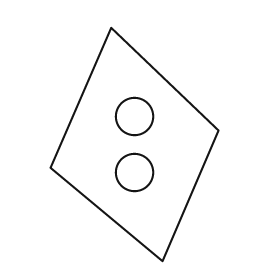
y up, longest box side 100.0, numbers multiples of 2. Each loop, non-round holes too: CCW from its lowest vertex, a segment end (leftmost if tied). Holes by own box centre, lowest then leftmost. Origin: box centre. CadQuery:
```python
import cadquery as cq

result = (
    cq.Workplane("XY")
    .moveTo(12.0, -50.0)
    .lineTo(36.0, 6.0)
    .lineTo(-10.0, 50.0)
    .lineTo(-36.0, -10.0)
    .close()
    .moveTo(0.0, -12.0)
    .circle(8.0)
    .moveTo(0.0, 12.0)
    .circle(8.0)
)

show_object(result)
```